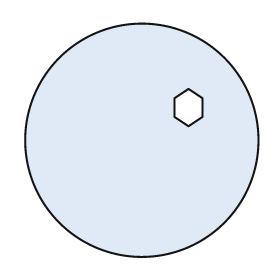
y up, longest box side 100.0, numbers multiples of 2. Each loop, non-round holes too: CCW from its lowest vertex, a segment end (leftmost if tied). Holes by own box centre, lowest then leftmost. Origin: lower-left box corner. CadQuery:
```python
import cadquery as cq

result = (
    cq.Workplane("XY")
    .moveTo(50.0, 50.0)
    .circle(50.0)
    .moveTo(70.0, 56.0)
    .lineTo(76.0, 60.0)
    .lineTo(76.0, 68.0)
    .lineTo(70.0, 72.0)
    .lineTo(64.0, 68.0)
    .lineTo(64.0, 60.0)
    .close()
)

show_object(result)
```